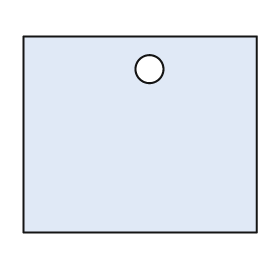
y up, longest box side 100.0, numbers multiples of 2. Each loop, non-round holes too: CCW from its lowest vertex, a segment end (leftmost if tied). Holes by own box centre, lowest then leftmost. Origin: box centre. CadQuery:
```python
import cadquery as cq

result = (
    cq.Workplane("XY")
    .moveTo(-50.0, -42.0)
    .lineTo(50.0, -42.0)
    .lineTo(50.0, 42.0)
    .lineTo(-50.0, 42.0)
    .close()
    .moveTo(4.0, 28.0)
    .circle(6.0)
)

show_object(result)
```